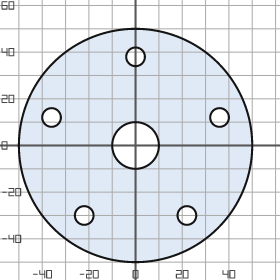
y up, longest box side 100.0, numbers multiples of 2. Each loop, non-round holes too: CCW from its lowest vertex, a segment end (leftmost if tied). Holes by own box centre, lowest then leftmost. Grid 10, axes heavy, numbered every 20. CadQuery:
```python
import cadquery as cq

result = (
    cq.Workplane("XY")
    .moveTo(0.0, 0.0)
    .circle(50.0)
    .moveTo(-22.0, -30.0)
    .circle(4.0)
    .moveTo(22.0, -30.0)
    .circle(4.0)
    .moveTo(0.0, 0.0)
    .circle(10.0)
    .moveTo(-36.0, 12.0)
    .circle(4.0)
    .moveTo(36.0, 12.0)
    .circle(4.0)
    .moveTo(0.0, 38.0)
    .circle(4.0)
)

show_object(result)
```